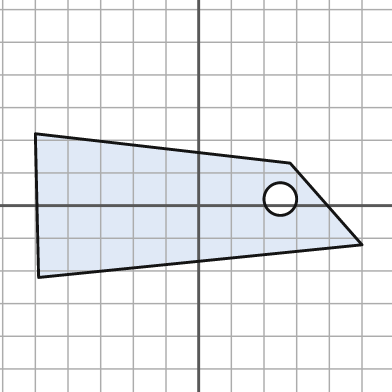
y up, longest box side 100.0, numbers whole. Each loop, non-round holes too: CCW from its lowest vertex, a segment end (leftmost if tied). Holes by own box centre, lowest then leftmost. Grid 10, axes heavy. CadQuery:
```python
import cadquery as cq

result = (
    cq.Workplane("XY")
    .moveTo(-49.0, -22.0)
    .lineTo(50.0, -12.0)
    .lineTo(28.0, 13.0)
    .lineTo(-50.0, 22.0)
    .close()
    .moveTo(25.0, 2.0)
    .circle(5.0)
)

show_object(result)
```